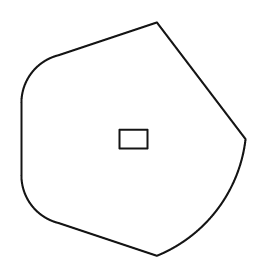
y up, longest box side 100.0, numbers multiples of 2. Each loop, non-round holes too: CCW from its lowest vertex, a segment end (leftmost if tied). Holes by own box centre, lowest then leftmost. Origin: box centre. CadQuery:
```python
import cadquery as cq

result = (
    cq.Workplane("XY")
    .moveTo(10.0, -50.0)
    .threePointArc((36.0, -30.0), (48.0, 0.0))
    .lineTo(10.0, 50.0)
    .lineTo(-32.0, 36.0)
    .threePointArc((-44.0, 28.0), (-48.0, 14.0))
    .lineTo(-48.0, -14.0)
    .threePointArc((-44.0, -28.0), (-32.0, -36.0))
    .close()
    .moveTo(-6.0, -4.0)
    .lineTo(6.0, -4.0)
    .lineTo(6.0, 4.0)
    .lineTo(-6.0, 4.0)
    .close()
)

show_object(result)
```